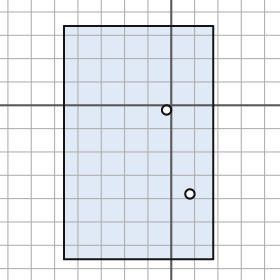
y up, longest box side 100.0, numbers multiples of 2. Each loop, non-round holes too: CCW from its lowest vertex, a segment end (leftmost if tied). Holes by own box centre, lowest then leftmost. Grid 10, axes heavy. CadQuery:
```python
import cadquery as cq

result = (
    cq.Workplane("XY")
    .moveTo(-46.0, -66.0)
    .lineTo(18.0, -66.0)
    .lineTo(18.0, 34.0)
    .lineTo(-46.0, 34.0)
    .close()
    .moveTo(8.0, -38.0)
    .circle(2.0)
    .moveTo(-2.0, -2.0)
    .circle(2.0)
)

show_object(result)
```